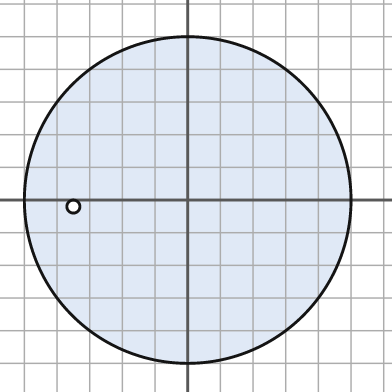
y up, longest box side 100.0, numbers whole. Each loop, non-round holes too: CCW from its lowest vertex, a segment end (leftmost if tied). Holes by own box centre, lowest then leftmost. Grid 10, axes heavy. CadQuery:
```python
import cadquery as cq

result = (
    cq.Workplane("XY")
    .moveTo(0.0, 0.0)
    .circle(50.0)
    .moveTo(-35.0, -2.0)
    .circle(2.0)
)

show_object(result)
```